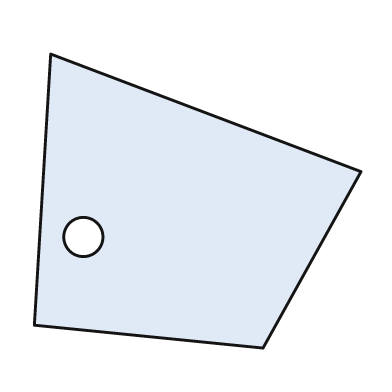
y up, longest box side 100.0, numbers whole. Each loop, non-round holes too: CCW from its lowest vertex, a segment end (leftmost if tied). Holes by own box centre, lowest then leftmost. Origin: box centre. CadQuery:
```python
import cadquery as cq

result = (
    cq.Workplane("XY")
    .moveTo(20.0, -45.0)
    .lineTo(50.0, 9.0)
    .lineTo(-45.0, 45.0)
    .lineTo(-50.0, -38.0)
    .close()
    .moveTo(-35.0, -11.0)
    .circle(6.0)
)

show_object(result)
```